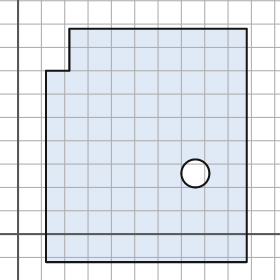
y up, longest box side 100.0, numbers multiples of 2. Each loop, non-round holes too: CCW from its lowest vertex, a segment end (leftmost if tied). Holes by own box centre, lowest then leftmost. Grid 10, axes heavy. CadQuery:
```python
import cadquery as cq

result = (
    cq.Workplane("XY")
    .moveTo(12.0, -12.0)
    .lineTo(98.0, -12.0)
    .lineTo(98.0, 88.0)
    .lineTo(22.0, 88.0)
    .lineTo(22.0, 70.0)
    .lineTo(12.0, 70.0)
    .close()
    .moveTo(76.0, 26.0)
    .circle(6.0)
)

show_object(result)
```